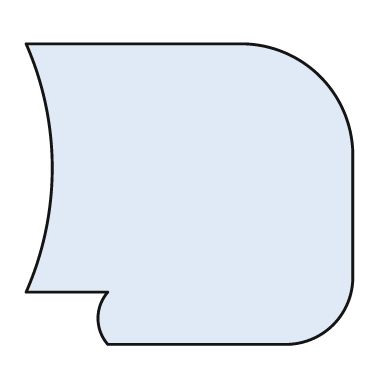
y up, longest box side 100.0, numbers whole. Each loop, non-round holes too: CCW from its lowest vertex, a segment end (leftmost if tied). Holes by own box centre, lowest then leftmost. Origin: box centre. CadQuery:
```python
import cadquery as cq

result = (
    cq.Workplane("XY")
    .moveTo(-25.0, -46.0)
    .lineTo(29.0, -46.0)
    .threePointArc((44.0, -40.0), (50.0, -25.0))
    .lineTo(50.0, 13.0)
    .threePointArc((40.0, 36.0), (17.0, 46.0))
    .lineTo(-50.0, 46.0)
    .threePointArc((-42.0, 8.0), (-50.0, -30.0))
    .lineTo(-25.0, -30.0)
    .threePointArc((-28.0, -38.0), (-25.0, -46.0))
    .close()
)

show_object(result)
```